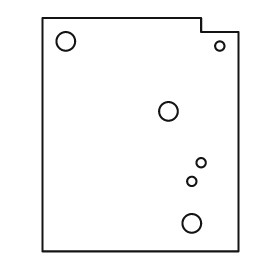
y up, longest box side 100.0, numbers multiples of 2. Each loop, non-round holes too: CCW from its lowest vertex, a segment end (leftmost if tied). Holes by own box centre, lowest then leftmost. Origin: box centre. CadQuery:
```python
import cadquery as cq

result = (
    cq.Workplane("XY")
    .moveTo(-42.0, -50.0)
    .lineTo(42.0, -50.0)
    .lineTo(42.0, 44.0)
    .lineTo(26.0, 44.0)
    .lineTo(26.0, 50.0)
    .lineTo(-42.0, 50.0)
    .close()
    .moveTo(22.0, -38.0)
    .circle(4.0)
    .moveTo(22.0, -20.0)
    .circle(2.0)
    .moveTo(26.0, -12.0)
    .circle(2.0)
    .moveTo(12.0, 10.0)
    .circle(4.0)
    .moveTo(34.0, 38.0)
    .circle(2.0)
    .moveTo(-32.0, 40.0)
    .circle(4.0)
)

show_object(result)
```